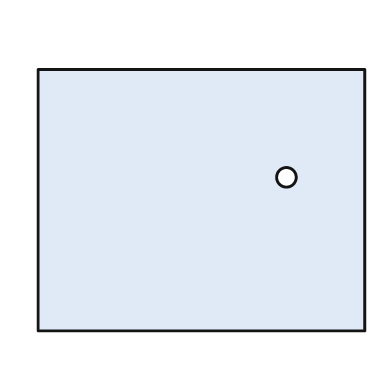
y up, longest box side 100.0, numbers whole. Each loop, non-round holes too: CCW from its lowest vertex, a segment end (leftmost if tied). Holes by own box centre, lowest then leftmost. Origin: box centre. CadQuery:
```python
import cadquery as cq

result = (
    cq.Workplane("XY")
    .moveTo(-50.0, -40.0)
    .lineTo(50.0, -40.0)
    .lineTo(50.0, 40.0)
    .lineTo(-50.0, 40.0)
    .close()
    .moveTo(26.0, 7.0)
    .circle(3.0)
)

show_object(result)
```